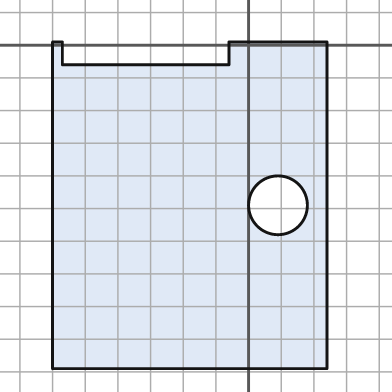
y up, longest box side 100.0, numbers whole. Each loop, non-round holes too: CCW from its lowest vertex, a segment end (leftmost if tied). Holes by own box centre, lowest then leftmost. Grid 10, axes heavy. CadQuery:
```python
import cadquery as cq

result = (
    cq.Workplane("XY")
    .moveTo(-60.0, -99.0)
    .lineTo(24.0, -99.0)
    .lineTo(24.0, 1.0)
    .lineTo(-6.0, 1.0)
    .lineTo(-6.0, -6.0)
    .lineTo(-57.0, -6.0)
    .lineTo(-57.0, 1.0)
    .lineTo(-60.0, 1.0)
    .close()
    .moveTo(9.0, -49.0)
    .circle(9.0)
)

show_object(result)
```